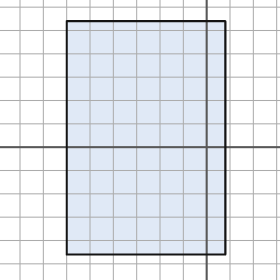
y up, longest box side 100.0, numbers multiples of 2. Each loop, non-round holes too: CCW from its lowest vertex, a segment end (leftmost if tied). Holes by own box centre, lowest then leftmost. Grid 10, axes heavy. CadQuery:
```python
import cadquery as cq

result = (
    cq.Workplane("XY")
    .moveTo(-60.0, -46.0)
    .lineTo(8.0, -46.0)
    .lineTo(8.0, 54.0)
    .lineTo(-60.0, 54.0)
    .close()
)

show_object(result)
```